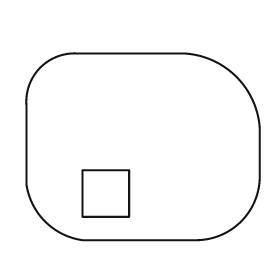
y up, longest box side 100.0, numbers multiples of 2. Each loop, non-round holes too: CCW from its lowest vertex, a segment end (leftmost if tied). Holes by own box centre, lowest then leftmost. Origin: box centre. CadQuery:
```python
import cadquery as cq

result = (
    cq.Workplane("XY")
    .moveTo(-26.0, -40.0)
    .lineTo(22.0, -40.0)
    .threePointArc((42.0, -32.0), (50.0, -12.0))
    .lineTo(50.0, 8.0)
    .threePointArc((40.0, 30.0), (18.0, 40.0))
    .lineTo(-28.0, 40.0)
    .threePointArc((-44.0, 34.0), (-50.0, 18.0))
    .lineTo(-50.0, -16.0)
    .threePointArc((-42.0, -32.0), (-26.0, -40.0))
    .close()
    .moveTo(-26.0, -30.0)
    .lineTo(-6.0, -30.0)
    .lineTo(-6.0, -10.0)
    .lineTo(-26.0, -10.0)
    .close()
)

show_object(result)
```